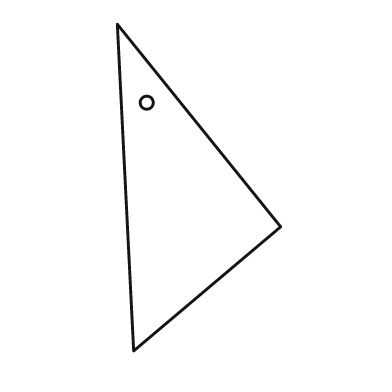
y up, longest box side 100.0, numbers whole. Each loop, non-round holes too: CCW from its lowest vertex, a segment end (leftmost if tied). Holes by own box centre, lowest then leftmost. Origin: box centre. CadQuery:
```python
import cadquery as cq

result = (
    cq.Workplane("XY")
    .moveTo(-20.0, -50.0)
    .lineTo(25.0, -12.0)
    .lineTo(-25.0, 50.0)
    .close()
    .moveTo(-16.0, 26.0)
    .circle(2.0)
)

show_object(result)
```